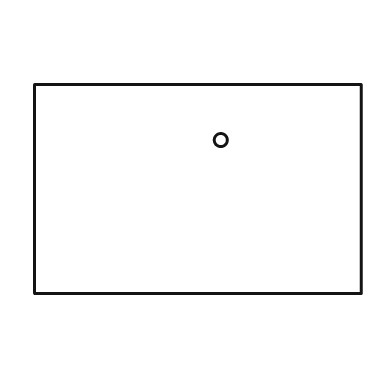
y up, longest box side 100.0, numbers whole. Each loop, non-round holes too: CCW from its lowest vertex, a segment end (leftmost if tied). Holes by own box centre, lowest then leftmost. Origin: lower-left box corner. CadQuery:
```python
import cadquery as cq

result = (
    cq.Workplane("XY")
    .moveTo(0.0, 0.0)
    .lineTo(100.0, 0.0)
    .lineTo(100.0, 64.0)
    .lineTo(0.0, 64.0)
    .close()
    .moveTo(57.0, 47.0)
    .circle(2.0)
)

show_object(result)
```